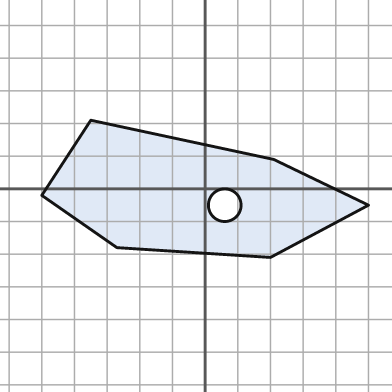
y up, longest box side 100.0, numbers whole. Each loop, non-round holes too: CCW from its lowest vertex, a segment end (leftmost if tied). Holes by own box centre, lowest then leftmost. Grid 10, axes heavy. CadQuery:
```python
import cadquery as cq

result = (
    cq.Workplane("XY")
    .moveTo(20.0, -21.0)
    .lineTo(50.0, -5.0)
    .lineTo(21.0, 9.0)
    .lineTo(-35.0, 21.0)
    .lineTo(-50.0, -2.0)
    .lineTo(-27.0, -18.0)
    .close()
    .moveTo(6.0, -5.0)
    .circle(5.0)
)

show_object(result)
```